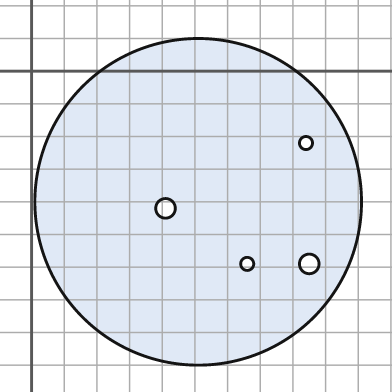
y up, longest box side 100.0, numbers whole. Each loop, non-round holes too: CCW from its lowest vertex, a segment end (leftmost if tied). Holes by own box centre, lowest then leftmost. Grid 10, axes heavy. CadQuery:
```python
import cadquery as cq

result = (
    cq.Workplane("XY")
    .moveTo(51.0, -40.0)
    .circle(50.0)
    .moveTo(66.0, -59.0)
    .circle(2.0)
    .moveTo(85.0, -59.0)
    .circle(3.0)
    .moveTo(41.0, -42.0)
    .circle(3.0)
    .moveTo(84.0, -22.0)
    .circle(2.0)
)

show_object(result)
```